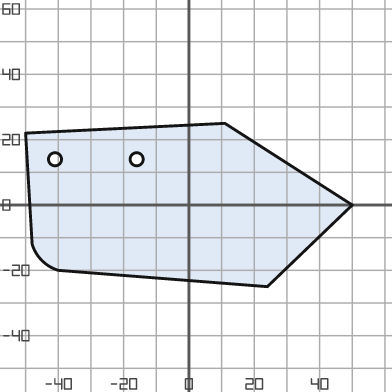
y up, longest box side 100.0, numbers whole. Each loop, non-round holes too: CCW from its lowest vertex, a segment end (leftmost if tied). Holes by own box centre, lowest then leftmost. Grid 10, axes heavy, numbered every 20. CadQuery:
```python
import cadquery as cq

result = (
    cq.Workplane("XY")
    .moveTo(24.0, -25.0)
    .lineTo(50.0, 0.0)
    .lineTo(11.0, 25.0)
    .lineTo(-50.0, 22.0)
    .lineTo(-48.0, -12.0)
    .threePointArc((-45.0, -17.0), (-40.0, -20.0))
    .close()
    .moveTo(-41.0, 14.0)
    .circle(2.0)
    .moveTo(-16.0, 14.0)
    .circle(2.0)
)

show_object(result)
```